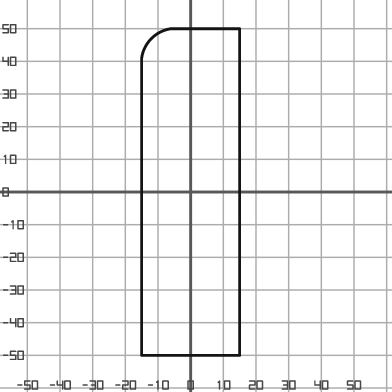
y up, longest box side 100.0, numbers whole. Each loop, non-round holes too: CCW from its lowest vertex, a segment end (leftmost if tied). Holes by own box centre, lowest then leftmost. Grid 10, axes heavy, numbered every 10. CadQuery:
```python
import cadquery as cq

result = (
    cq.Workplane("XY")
    .moveTo(-15.0, -50.0)
    .lineTo(15.0, -50.0)
    .lineTo(15.0, 50.0)
    .lineTo(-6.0, 50.0)
    .threePointArc((-12.0, 47.0), (-15.0, 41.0))
    .close()
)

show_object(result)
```